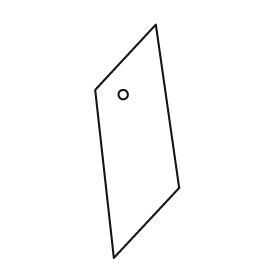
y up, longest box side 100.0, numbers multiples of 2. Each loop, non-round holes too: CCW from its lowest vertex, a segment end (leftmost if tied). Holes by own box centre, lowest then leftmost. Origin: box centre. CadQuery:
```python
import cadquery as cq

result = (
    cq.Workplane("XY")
    .moveTo(-10.0, -50.0)
    .lineTo(18.0, -20.0)
    .lineTo(8.0, 50.0)
    .lineTo(-18.0, 22.0)
    .close()
    .moveTo(-6.0, 20.0)
    .circle(2.0)
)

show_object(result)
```